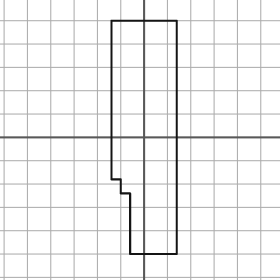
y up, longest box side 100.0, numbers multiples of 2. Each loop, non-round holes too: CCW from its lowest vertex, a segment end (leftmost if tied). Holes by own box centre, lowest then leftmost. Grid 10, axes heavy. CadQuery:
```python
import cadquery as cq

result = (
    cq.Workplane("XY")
    .moveTo(-6.0, -50.0)
    .lineTo(14.0, -50.0)
    .lineTo(14.0, 50.0)
    .lineTo(-14.0, 50.0)
    .lineTo(-14.0, -18.0)
    .lineTo(-10.0, -18.0)
    .lineTo(-10.0, -24.0)
    .lineTo(-6.0, -24.0)
    .close()
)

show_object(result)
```